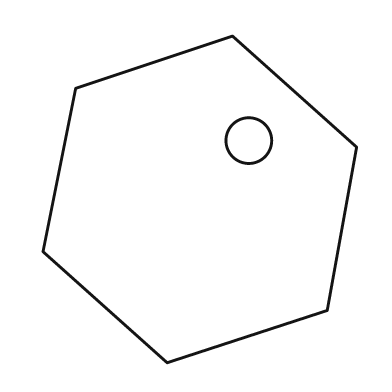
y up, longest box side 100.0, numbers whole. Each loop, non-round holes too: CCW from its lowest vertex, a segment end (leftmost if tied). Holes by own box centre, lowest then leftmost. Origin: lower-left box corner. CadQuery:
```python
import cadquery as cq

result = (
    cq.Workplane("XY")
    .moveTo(38.0, 0.0)
    .lineTo(87.0, 16.0)
    .lineTo(96.0, 66.0)
    .lineTo(58.0, 100.0)
    .lineTo(10.0, 84.0)
    .lineTo(0.0, 34.0)
    .close()
    .moveTo(63.0, 68.0)
    .circle(7.0)
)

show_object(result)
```